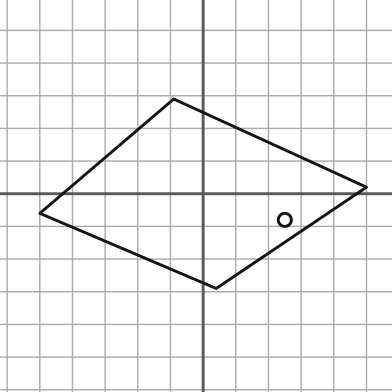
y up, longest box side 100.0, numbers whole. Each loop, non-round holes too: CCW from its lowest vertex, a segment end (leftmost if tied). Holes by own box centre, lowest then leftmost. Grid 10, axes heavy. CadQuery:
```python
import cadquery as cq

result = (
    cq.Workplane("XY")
    .moveTo(4.0, -29.0)
    .lineTo(50.0, 2.0)
    .lineTo(-9.0, 29.0)
    .lineTo(-50.0, -6.0)
    .close()
    .moveTo(25.0, -8.0)
    .circle(2.0)
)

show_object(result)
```